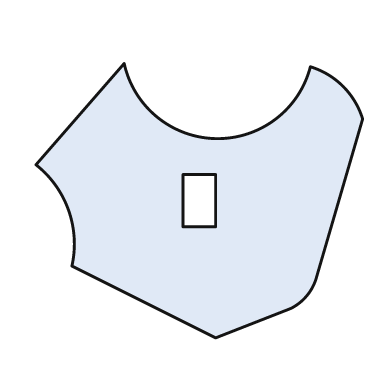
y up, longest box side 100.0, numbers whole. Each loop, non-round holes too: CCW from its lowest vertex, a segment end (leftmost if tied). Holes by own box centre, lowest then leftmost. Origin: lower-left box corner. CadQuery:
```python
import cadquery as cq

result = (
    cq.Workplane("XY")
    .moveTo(55.0, 0.0)
    .lineTo(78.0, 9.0)
    .threePointArc((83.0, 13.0), (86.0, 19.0))
    .lineTo(100.0, 67.0)
    .threePointArc((94.0, 77.0), (84.0, 83.0))
    .threePointArc((55.0, 61.0), (27.0, 84.0))
    .lineTo(0.0, 53.0)
    .threePointArc((10.0, 39.0), (11.0, 22.0))
    .close()
    .moveTo(45.0, 34.0)
    .lineTo(55.0, 34.0)
    .lineTo(55.0, 50.0)
    .lineTo(45.0, 50.0)
    .close()
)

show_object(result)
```